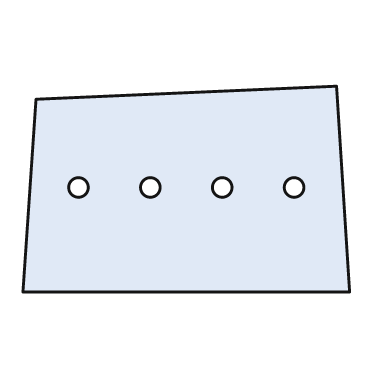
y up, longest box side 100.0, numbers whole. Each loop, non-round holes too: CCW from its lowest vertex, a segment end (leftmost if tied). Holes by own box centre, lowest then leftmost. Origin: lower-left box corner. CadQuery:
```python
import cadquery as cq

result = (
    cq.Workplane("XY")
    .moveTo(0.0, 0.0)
    .lineTo(100.0, 0.0)
    .lineTo(96.0, 63.0)
    .lineTo(4.0, 59.0)
    .close()
    .moveTo(17.0, 32.0)
    .circle(3.0)
    .moveTo(39.0, 32.0)
    .circle(3.0)
    .moveTo(61.0, 32.0)
    .circle(3.0)
    .moveTo(83.0, 32.0)
    .circle(3.0)
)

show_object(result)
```